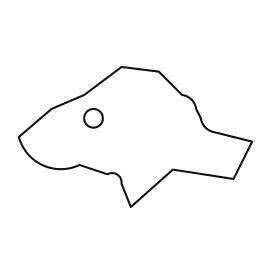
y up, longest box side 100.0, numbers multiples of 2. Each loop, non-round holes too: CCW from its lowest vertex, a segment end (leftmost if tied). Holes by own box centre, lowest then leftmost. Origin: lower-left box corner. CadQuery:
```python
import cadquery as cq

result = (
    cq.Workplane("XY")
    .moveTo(48.0, 0.0)
    .lineTo(66.0, 16.0)
    .lineTo(92.0, 12.0)
    .lineTo(100.0, 28.0)
    .lineTo(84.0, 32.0)
    .threePointArc((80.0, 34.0), (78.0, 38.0))
    .lineTo(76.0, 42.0)
    .threePointArc((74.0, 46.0), (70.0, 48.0))
    .lineTo(60.0, 58.0)
    .lineTo(44.0, 60.0)
    .lineTo(28.0, 48.0)
    .lineTo(14.0, 42.0)
    .lineTo(0.0, 30.0)
    .threePointArc((10.0, 18.0), (26.0, 18.0))
    .lineTo(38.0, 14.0)
    .threePointArc((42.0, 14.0), (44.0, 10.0))
    .close()
    .moveTo(32.0, 38.0)
    .circle(4.0)
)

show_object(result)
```